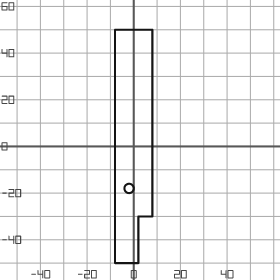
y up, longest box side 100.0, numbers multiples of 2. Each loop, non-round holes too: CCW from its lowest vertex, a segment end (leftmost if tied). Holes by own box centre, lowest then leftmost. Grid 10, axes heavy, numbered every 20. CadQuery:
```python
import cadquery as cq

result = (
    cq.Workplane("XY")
    .moveTo(-8.0, -50.0)
    .lineTo(2.0, -50.0)
    .lineTo(2.0, -30.0)
    .lineTo(8.0, -30.0)
    .lineTo(8.0, 50.0)
    .lineTo(-8.0, 50.0)
    .close()
    .moveTo(-2.0, -18.0)
    .circle(2.0)
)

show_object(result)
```